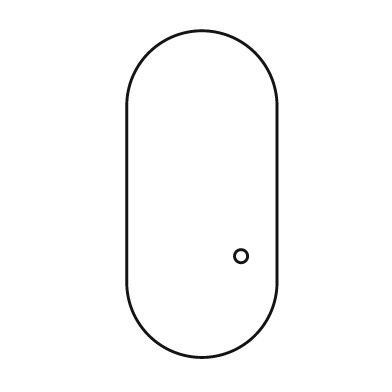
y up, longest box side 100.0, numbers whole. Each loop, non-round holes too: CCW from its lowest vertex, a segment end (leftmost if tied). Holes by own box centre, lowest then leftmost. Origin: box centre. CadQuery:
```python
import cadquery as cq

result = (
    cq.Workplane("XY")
    .moveTo(-23.0, -27.0)
    .threePointArc((0.0, -50.0), (23.0, -27.0))
    .lineTo(23.0, 27.0)
    .threePointArc((0.0, 50.0), (-23.0, 27.0))
    .close()
    .moveTo(12.0, -19.0)
    .circle(2.0)
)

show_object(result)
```